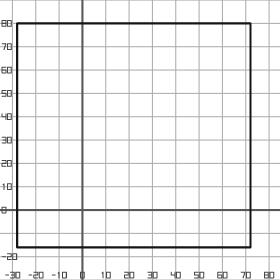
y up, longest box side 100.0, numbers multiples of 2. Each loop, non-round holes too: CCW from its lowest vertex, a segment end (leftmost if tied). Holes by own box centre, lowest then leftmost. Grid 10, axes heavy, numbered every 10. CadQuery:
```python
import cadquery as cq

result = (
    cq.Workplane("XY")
    .moveTo(-28.0, -16.0)
    .lineTo(72.0, -16.0)
    .lineTo(72.0, 80.0)
    .lineTo(-28.0, 80.0)
    .close()
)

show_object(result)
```